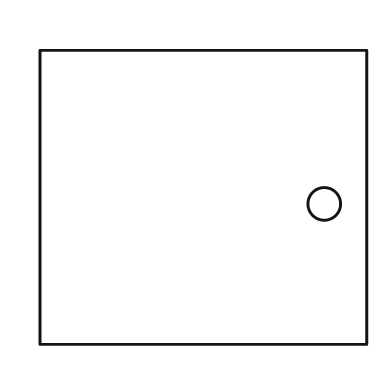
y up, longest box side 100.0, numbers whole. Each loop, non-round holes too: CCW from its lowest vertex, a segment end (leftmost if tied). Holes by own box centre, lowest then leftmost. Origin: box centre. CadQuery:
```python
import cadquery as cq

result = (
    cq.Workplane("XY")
    .moveTo(-50.0, -45.0)
    .lineTo(50.0, -45.0)
    .lineTo(50.0, 45.0)
    .lineTo(-50.0, 45.0)
    .close()
    .moveTo(37.0, -2.0)
    .circle(5.0)
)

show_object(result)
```